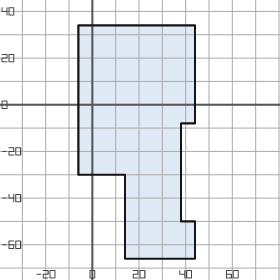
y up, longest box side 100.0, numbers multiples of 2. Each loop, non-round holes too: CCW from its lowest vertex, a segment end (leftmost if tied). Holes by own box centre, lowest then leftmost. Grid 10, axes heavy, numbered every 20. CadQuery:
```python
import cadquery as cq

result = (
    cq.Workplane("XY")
    .moveTo(14.0, -66.0)
    .lineTo(44.0, -66.0)
    .lineTo(44.0, -50.0)
    .lineTo(38.0, -50.0)
    .lineTo(38.0, -8.0)
    .lineTo(44.0, -8.0)
    .lineTo(44.0, 34.0)
    .lineTo(-6.0, 34.0)
    .lineTo(-6.0, -30.0)
    .lineTo(14.0, -30.0)
    .close()
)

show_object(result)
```